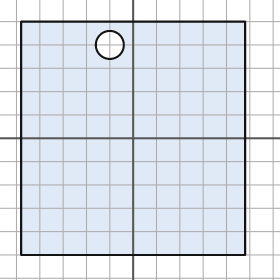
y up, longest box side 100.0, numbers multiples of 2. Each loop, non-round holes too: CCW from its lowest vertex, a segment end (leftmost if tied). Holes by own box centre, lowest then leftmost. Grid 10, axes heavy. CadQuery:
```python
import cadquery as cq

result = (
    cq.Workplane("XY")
    .moveTo(-48.0, -50.0)
    .lineTo(48.0, -50.0)
    .lineTo(48.0, 50.0)
    .lineTo(-48.0, 50.0)
    .close()
    .moveTo(-10.0, 40.0)
    .circle(6.0)
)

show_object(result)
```